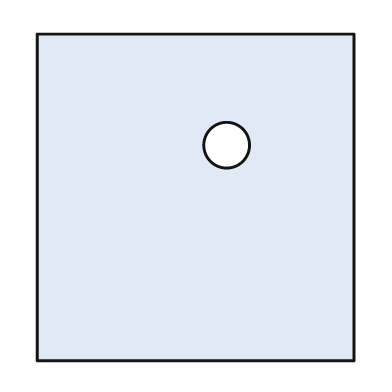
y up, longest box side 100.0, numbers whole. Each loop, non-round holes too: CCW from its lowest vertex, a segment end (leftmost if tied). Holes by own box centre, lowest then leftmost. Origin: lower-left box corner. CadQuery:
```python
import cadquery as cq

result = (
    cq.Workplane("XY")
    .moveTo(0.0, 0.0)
    .lineTo(97.0, 0.0)
    .lineTo(97.0, 100.0)
    .lineTo(0.0, 100.0)
    .close()
    .moveTo(58.0, 66.0)
    .circle(7.0)
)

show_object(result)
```